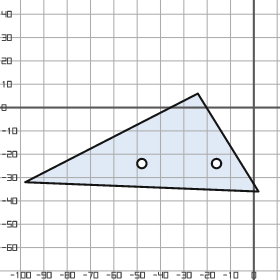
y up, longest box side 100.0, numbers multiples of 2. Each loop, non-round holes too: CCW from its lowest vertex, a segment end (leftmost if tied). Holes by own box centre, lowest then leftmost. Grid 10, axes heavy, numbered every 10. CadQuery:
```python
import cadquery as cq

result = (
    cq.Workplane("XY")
    .moveTo(2.0, -36.0)
    .lineTo(-24.0, 6.0)
    .lineTo(-98.0, -32.0)
    .close()
    .moveTo(-48.0, -24.0)
    .circle(2.0)
    .moveTo(-16.0, -24.0)
    .circle(2.0)
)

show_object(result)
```